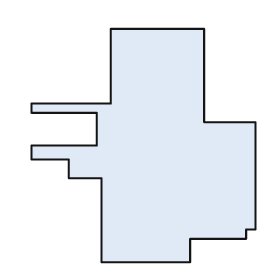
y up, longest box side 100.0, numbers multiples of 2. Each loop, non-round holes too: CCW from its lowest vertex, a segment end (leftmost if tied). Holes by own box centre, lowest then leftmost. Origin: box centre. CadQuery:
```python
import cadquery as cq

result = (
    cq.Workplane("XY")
    .moveTo(-18.0, -50.0)
    .lineTo(20.0, -50.0)
    .lineTo(20.0, -40.0)
    .lineTo(44.0, -40.0)
    .lineTo(44.0, -36.0)
    .lineTo(48.0, -36.0)
    .lineTo(48.0, 10.0)
    .lineTo(26.0, 10.0)
    .lineTo(26.0, 50.0)
    .lineTo(-14.0, 50.0)
    .lineTo(-14.0, 18.0)
    .lineTo(-48.0, 18.0)
    .lineTo(-48.0, 14.0)
    .lineTo(-20.0, 14.0)
    .lineTo(-20.0, 0.0)
    .lineTo(-48.0, 0.0)
    .lineTo(-48.0, -6.0)
    .lineTo(-32.0, -6.0)
    .lineTo(-32.0, -14.0)
    .lineTo(-18.0, -14.0)
    .close()
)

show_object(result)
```